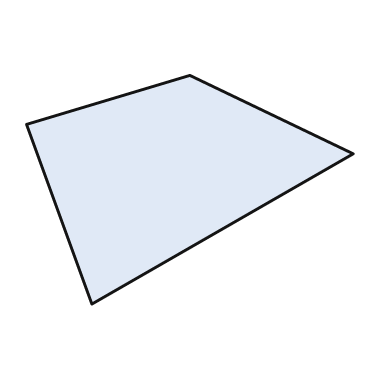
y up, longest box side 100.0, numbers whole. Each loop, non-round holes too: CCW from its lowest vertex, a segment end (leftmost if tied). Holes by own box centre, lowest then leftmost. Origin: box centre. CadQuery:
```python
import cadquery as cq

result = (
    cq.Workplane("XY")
    .moveTo(-30.0, -35.0)
    .lineTo(50.0, 11.0)
    .lineTo(0.0, 35.0)
    .lineTo(-50.0, 20.0)
    .close()
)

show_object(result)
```